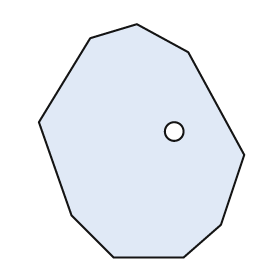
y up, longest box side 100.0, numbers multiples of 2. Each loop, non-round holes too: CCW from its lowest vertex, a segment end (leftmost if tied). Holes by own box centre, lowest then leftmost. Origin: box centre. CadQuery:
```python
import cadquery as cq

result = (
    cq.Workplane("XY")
    .moveTo(-12.0, -50.0)
    .lineTo(18.0, -50.0)
    .lineTo(34.0, -36.0)
    .lineTo(44.0, -6.0)
    .lineTo(20.0, 38.0)
    .lineTo(-2.0, 50.0)
    .lineTo(-22.0, 44.0)
    .lineTo(-44.0, 8.0)
    .lineTo(-30.0, -32.0)
    .close()
    .moveTo(14.0, 4.0)
    .circle(4.0)
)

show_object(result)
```